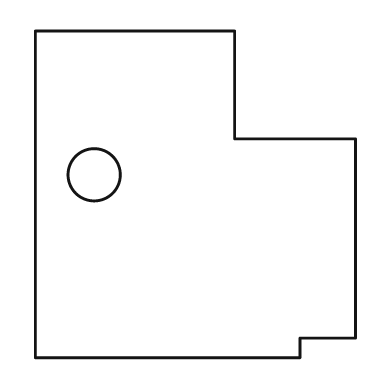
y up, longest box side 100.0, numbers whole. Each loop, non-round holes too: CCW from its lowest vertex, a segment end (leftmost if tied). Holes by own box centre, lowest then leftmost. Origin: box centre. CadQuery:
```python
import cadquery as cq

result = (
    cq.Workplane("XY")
    .moveTo(-49.0, -50.0)
    .lineTo(32.0, -50.0)
    .lineTo(32.0, -44.0)
    .lineTo(49.0, -44.0)
    .lineTo(49.0, 17.0)
    .lineTo(12.0, 17.0)
    .lineTo(12.0, 50.0)
    .lineTo(-49.0, 50.0)
    .close()
    .moveTo(-31.0, 6.0)
    .circle(8.0)
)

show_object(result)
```